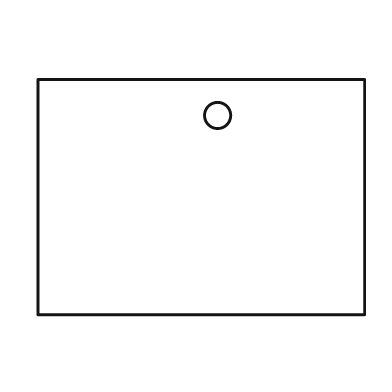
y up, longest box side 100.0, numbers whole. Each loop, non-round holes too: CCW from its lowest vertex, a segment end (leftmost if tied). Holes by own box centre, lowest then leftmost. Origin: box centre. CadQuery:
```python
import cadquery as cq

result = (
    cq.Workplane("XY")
    .moveTo(-50.0, -36.0)
    .lineTo(50.0, -36.0)
    .lineTo(50.0, 36.0)
    .lineTo(-50.0, 36.0)
    .close()
    .moveTo(5.0, 25.0)
    .circle(4.0)
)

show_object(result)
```